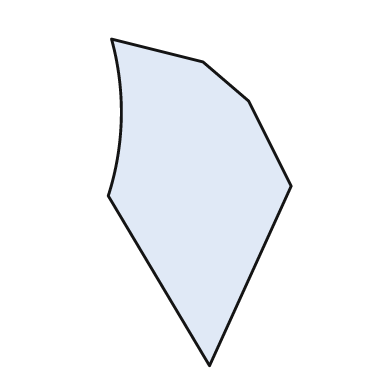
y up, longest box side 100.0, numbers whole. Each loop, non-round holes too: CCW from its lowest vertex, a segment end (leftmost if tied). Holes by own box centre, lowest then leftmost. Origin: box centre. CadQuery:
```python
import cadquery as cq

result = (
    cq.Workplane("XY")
    .moveTo(3.0, -50.0)
    .lineTo(28.0, 5.0)
    .lineTo(15.0, 31.0)
    .lineTo(1.0, 43.0)
    .lineTo(-27.0, 50.0)
    .threePointArc((-24.0, 26.0), (-28.0, 2.0))
    .close()
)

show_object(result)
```